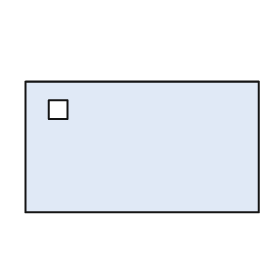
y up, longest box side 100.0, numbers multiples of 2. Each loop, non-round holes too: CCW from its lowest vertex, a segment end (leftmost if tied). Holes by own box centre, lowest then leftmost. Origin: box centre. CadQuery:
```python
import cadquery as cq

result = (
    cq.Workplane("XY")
    .moveTo(-50.0, -28.0)
    .lineTo(50.0, -28.0)
    .lineTo(50.0, 28.0)
    .lineTo(-50.0, 28.0)
    .close()
    .moveTo(-40.0, 12.0)
    .lineTo(-32.0, 12.0)
    .lineTo(-32.0, 20.0)
    .lineTo(-40.0, 20.0)
    .close()
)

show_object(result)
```